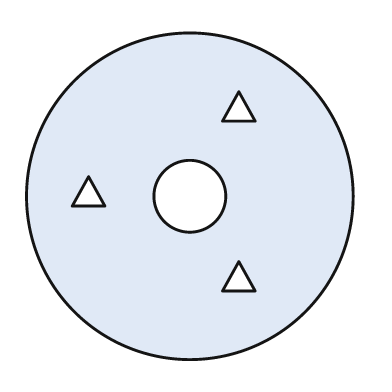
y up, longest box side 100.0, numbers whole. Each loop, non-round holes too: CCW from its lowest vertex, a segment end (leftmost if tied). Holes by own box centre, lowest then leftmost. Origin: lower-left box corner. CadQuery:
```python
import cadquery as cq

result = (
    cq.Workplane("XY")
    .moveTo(50.0, 50.0)
    .circle(50.0)
    .moveTo(60.0, 21.0)
    .lineTo(70.0, 21.0)
    .lineTo(65.0, 30.0)
    .close()
    .moveTo(50.0, 50.0)
    .circle(11.0)
    .moveTo(14.0, 47.0)
    .lineTo(24.0, 47.0)
    .lineTo(19.0, 56.0)
    .close()
    .moveTo(60.0, 73.0)
    .lineTo(70.0, 73.0)
    .lineTo(65.0, 82.0)
    .close()
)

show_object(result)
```